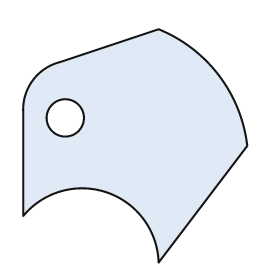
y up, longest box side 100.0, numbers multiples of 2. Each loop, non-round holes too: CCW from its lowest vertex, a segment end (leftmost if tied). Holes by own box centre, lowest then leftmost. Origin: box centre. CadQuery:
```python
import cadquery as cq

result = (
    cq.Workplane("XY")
    .moveTo(10.0, -50.0)
    .lineTo(48.0, 0.0)
    .threePointArc((36.0, 30.0), (10.0, 50.0))
    .lineTo(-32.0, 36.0)
    .threePointArc((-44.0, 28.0), (-48.0, 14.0))
    .lineTo(-48.0, -30.0)
    .threePointArc((-12.0, -20.0), (10.0, -50.0))
    .close()
    .moveTo(-30.0, 12.0)
    .circle(8.0)
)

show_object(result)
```